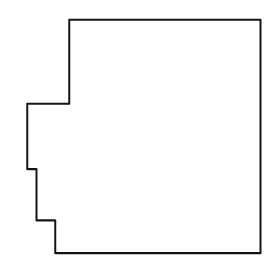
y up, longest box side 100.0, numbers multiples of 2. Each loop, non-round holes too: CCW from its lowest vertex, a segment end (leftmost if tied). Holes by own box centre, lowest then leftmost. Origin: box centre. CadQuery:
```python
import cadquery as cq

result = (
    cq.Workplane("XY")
    .moveTo(-38.0, -50.0)
    .lineTo(50.0, -50.0)
    .lineTo(50.0, 50.0)
    .lineTo(-32.0, 50.0)
    .lineTo(-32.0, 14.0)
    .lineTo(-50.0, 14.0)
    .lineTo(-50.0, -14.0)
    .lineTo(-46.0, -14.0)
    .lineTo(-46.0, -36.0)
    .lineTo(-38.0, -36.0)
    .close()
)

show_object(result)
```